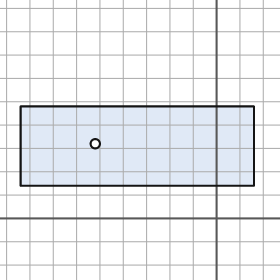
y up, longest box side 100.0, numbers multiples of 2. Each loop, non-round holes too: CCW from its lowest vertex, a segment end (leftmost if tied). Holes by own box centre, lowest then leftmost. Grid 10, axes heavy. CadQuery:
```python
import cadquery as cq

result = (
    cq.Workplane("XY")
    .moveTo(-84.0, 14.0)
    .lineTo(16.0, 14.0)
    .lineTo(16.0, 48.0)
    .lineTo(-84.0, 48.0)
    .close()
    .moveTo(-52.0, 32.0)
    .circle(2.0)
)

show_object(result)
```